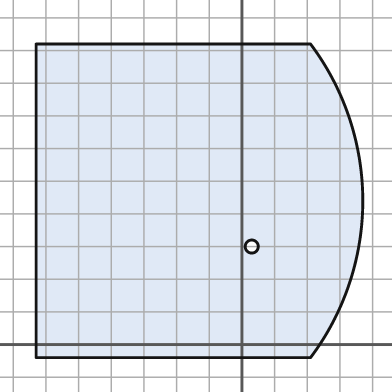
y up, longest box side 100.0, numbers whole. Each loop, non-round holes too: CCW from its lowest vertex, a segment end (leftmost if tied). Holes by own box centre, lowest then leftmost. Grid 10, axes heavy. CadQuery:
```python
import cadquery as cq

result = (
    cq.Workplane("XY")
    .moveTo(-63.0, -4.0)
    .lineTo(21.0, -4.0)
    .threePointArc((37.0, 44.0), (21.0, 92.0))
    .lineTo(-63.0, 92.0)
    .close()
    .moveTo(3.0, 30.0)
    .circle(2.0)
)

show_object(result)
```